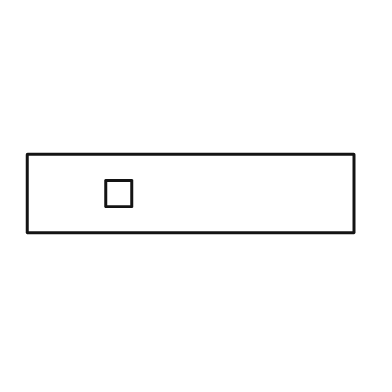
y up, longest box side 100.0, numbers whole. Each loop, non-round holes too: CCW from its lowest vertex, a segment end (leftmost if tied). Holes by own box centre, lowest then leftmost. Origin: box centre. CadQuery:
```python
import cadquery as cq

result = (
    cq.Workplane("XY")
    .moveTo(-50.0, -12.0)
    .lineTo(50.0, -12.0)
    .lineTo(50.0, 12.0)
    .lineTo(-50.0, 12.0)
    .close()
    .moveTo(-26.0, -4.0)
    .lineTo(-18.0, -4.0)
    .lineTo(-18.0, 4.0)
    .lineTo(-26.0, 4.0)
    .close()
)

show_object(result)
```